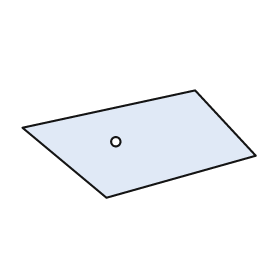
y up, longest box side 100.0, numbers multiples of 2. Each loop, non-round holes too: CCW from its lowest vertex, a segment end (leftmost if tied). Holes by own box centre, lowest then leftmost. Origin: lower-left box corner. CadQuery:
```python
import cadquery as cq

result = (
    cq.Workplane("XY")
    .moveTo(36.0, 0.0)
    .lineTo(100.0, 18.0)
    .lineTo(74.0, 46.0)
    .lineTo(0.0, 30.0)
    .close()
    .moveTo(40.0, 24.0)
    .circle(2.0)
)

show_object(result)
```